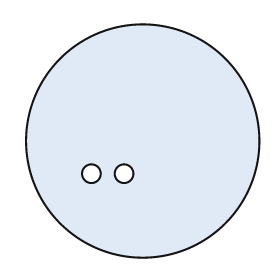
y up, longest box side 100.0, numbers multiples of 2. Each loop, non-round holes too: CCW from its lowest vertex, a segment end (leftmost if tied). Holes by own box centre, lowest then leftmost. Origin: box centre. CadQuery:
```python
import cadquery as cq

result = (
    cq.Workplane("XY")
    .moveTo(0.0, 0.0)
    .circle(50.0)
    .moveTo(-22.0, -14.0)
    .circle(4.0)
    .moveTo(-8.0, -14.0)
    .circle(4.0)
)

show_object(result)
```